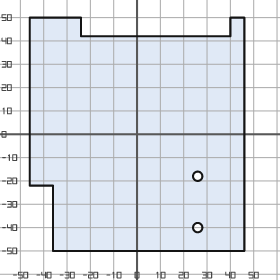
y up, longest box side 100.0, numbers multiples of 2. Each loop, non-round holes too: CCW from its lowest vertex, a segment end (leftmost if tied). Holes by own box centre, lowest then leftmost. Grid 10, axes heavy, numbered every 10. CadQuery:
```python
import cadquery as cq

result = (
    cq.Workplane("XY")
    .moveTo(-36.0, -50.0)
    .lineTo(46.0, -50.0)
    .lineTo(46.0, 50.0)
    .lineTo(40.0, 50.0)
    .lineTo(40.0, 42.0)
    .lineTo(-24.0, 42.0)
    .lineTo(-24.0, 50.0)
    .lineTo(-46.0, 50.0)
    .lineTo(-46.0, -22.0)
    .lineTo(-36.0, -22.0)
    .close()
    .moveTo(26.0, -40.0)
    .circle(2.0)
    .moveTo(26.0, -18.0)
    .circle(2.0)
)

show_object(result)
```